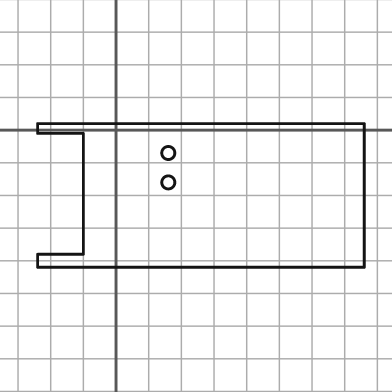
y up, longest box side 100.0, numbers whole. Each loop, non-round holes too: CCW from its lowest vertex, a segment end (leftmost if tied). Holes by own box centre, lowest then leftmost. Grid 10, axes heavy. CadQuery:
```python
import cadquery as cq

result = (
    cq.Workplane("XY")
    .moveTo(-24.0, -42.0)
    .lineTo(76.0, -42.0)
    .lineTo(76.0, 2.0)
    .lineTo(-24.0, 2.0)
    .lineTo(-24.0, -1.0)
    .lineTo(-10.0, -1.0)
    .lineTo(-10.0, -38.0)
    .lineTo(-24.0, -38.0)
    .close()
    .moveTo(16.0, -16.0)
    .circle(2.0)
    .moveTo(16.0, -7.0)
    .circle(2.0)
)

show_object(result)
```